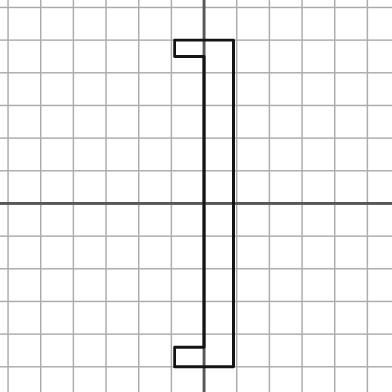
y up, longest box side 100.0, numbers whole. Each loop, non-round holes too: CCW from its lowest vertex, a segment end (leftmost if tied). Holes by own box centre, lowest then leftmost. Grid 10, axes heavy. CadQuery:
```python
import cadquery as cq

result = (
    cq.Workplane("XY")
    .moveTo(-9.0, -50.0)
    .lineTo(9.0, -50.0)
    .lineTo(9.0, 50.0)
    .lineTo(-9.0, 50.0)
    .lineTo(-9.0, 45.0)
    .lineTo(0.0, 45.0)
    .lineTo(0.0, -44.0)
    .lineTo(-9.0, -44.0)
    .close()
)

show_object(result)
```